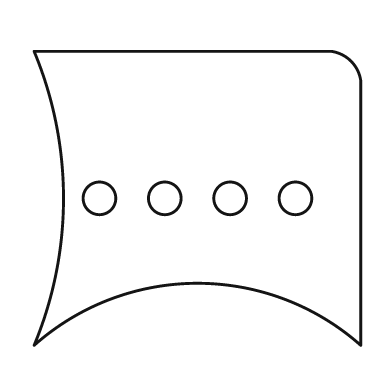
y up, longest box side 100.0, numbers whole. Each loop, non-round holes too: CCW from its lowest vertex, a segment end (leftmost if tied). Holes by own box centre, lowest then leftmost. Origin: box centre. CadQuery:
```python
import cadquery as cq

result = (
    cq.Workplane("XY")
    .moveTo(-50.0, -45.0)
    .threePointArc((0.0, -26.0), (50.0, -45.0))
    .lineTo(50.0, 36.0)
    .threePointArc((47.0, 42.0), (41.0, 45.0))
    .lineTo(-50.0, 45.0)
    .threePointArc((-41.0, 0.0), (-50.0, -45.0))
    .close()
    .moveTo(-30.0, 0.0)
    .circle(5.0)
    .moveTo(-10.0, 0.0)
    .circle(5.0)
    .moveTo(10.0, 0.0)
    .circle(5.0)
    .moveTo(30.0, 0.0)
    .circle(5.0)
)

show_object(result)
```